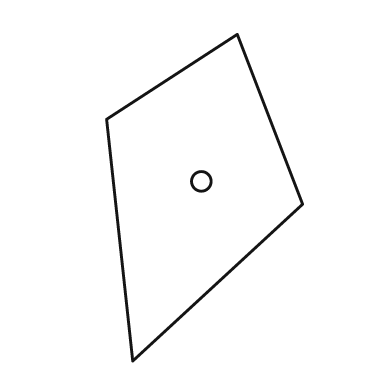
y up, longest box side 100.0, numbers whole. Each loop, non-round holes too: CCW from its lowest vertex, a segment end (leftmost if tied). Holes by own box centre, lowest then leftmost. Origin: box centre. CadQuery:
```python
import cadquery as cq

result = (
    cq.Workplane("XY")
    .moveTo(-22.0, -50.0)
    .lineTo(30.0, -2.0)
    .lineTo(10.0, 50.0)
    .lineTo(-30.0, 24.0)
    .close()
    .moveTo(-1.0, 5.0)
    .circle(3.0)
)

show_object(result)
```